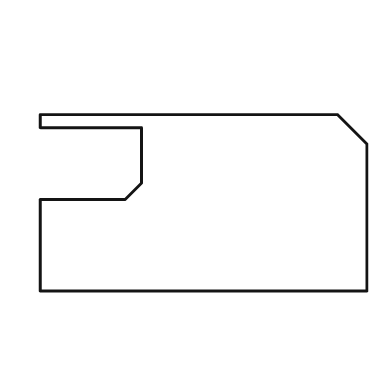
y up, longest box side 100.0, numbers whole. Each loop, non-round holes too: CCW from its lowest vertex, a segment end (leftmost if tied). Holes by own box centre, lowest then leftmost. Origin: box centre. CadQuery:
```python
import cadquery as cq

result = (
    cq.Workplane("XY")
    .moveTo(-50.0, -27.0)
    .lineTo(50.0, -27.0)
    .lineTo(50.0, 18.0)
    .lineTo(41.0, 27.0)
    .lineTo(-50.0, 27.0)
    .lineTo(-50.0, 23.0)
    .lineTo(-19.0, 23.0)
    .lineTo(-19.0, 6.0)
    .lineTo(-24.0, 1.0)
    .lineTo(-50.0, 1.0)
    .close()
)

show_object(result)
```